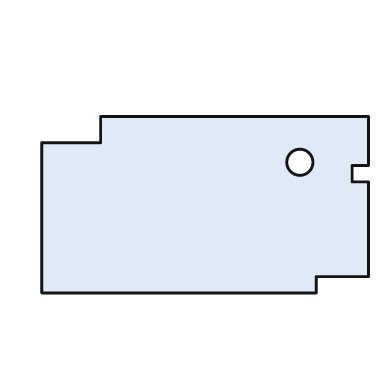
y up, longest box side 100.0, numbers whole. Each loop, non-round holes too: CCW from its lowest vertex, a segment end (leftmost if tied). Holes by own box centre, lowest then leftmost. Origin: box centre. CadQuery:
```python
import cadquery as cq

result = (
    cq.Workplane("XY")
    .moveTo(-50.0, -27.0)
    .lineTo(34.0, -27.0)
    .lineTo(34.0, -22.0)
    .lineTo(50.0, -22.0)
    .lineTo(50.0, 7.0)
    .lineTo(45.0, 7.0)
    .lineTo(45.0, 12.0)
    .lineTo(50.0, 12.0)
    .lineTo(50.0, 27.0)
    .lineTo(-32.0, 27.0)
    .lineTo(-32.0, 19.0)
    .lineTo(-50.0, 19.0)
    .close()
    .moveTo(29.0, 13.0)
    .circle(4.0)
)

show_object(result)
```